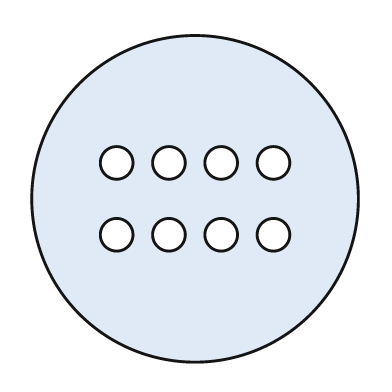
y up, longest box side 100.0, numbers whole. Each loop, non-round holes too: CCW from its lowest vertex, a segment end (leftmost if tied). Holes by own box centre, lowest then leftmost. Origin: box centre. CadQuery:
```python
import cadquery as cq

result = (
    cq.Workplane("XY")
    .moveTo(0.0, 0.0)
    .circle(50.0)
    .moveTo(-24.0, -11.0)
    .circle(5.0)
    .moveTo(-8.0, -11.0)
    .circle(5.0)
    .moveTo(8.0, -11.0)
    .circle(5.0)
    .moveTo(24.0, -11.0)
    .circle(5.0)
    .moveTo(-24.0, 11.0)
    .circle(5.0)
    .moveTo(-8.0, 11.0)
    .circle(5.0)
    .moveTo(8.0, 11.0)
    .circle(5.0)
    .moveTo(24.0, 11.0)
    .circle(5.0)
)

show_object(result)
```